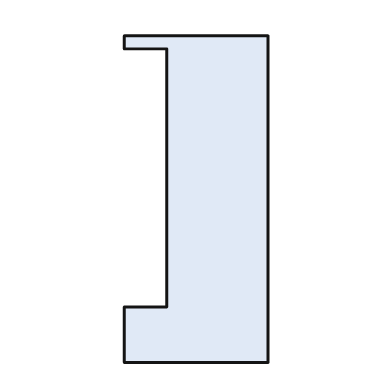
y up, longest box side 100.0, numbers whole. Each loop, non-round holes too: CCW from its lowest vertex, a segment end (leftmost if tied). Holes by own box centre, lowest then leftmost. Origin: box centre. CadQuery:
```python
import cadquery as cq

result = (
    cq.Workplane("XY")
    .moveTo(-22.0, -50.0)
    .lineTo(22.0, -50.0)
    .lineTo(22.0, 50.0)
    .lineTo(-22.0, 50.0)
    .lineTo(-22.0, 46.0)
    .lineTo(-9.0, 46.0)
    .lineTo(-9.0, -33.0)
    .lineTo(-22.0, -33.0)
    .close()
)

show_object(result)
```